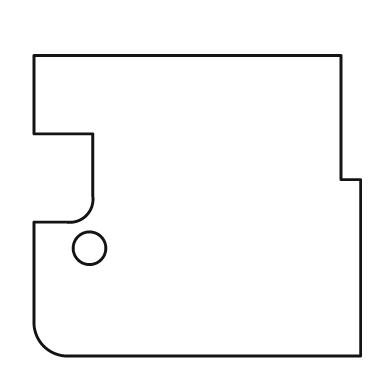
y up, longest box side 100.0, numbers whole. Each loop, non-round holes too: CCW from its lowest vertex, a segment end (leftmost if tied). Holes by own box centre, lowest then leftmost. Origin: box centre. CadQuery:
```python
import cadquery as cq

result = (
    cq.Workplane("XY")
    .moveTo(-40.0, -46.0)
    .lineTo(50.0, -46.0)
    .lineTo(50.0, 8.0)
    .lineTo(44.0, 8.0)
    .lineTo(44.0, 46.0)
    .lineTo(-50.0, 46.0)
    .lineTo(-50.0, 22.0)
    .lineTo(-32.0, 22.0)
    .lineTo(-32.0, 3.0)
    .threePointArc((-34.0, -3.0), (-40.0, -5.0))
    .lineTo(-50.0, -5.0)
    .lineTo(-50.0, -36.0)
    .threePointArc((-47.0, -43.0), (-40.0, -46.0))
    .close()
    .moveTo(-33.0, -13.0)
    .circle(5.0)
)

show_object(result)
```